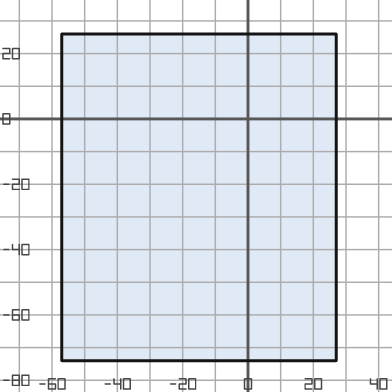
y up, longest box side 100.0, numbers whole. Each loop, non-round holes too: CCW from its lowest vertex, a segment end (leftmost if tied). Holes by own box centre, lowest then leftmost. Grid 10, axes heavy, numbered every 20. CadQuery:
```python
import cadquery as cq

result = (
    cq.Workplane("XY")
    .moveTo(-57.0, -74.0)
    .lineTo(27.0, -74.0)
    .lineTo(27.0, 26.0)
    .lineTo(-57.0, 26.0)
    .close()
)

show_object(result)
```